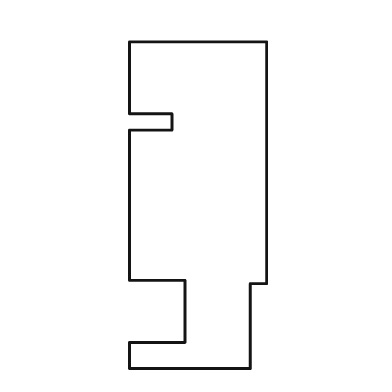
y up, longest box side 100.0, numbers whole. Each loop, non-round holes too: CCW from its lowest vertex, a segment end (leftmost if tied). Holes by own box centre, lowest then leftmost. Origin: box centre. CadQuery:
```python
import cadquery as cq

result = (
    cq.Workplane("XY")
    .moveTo(-21.0, -50.0)
    .lineTo(16.0, -50.0)
    .lineTo(16.0, -24.0)
    .lineTo(21.0, -24.0)
    .lineTo(21.0, 50.0)
    .lineTo(-21.0, 50.0)
    .lineTo(-21.0, 28.0)
    .lineTo(-8.0, 28.0)
    .lineTo(-8.0, 23.0)
    .lineTo(-21.0, 23.0)
    .lineTo(-21.0, -23.0)
    .lineTo(-4.0, -23.0)
    .lineTo(-4.0, -42.0)
    .lineTo(-21.0, -42.0)
    .close()
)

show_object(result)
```